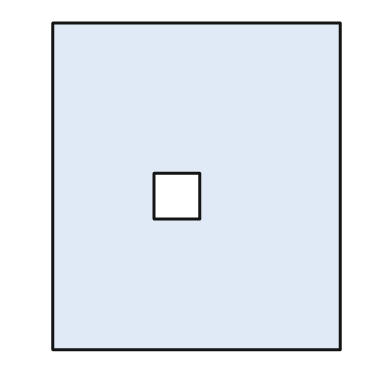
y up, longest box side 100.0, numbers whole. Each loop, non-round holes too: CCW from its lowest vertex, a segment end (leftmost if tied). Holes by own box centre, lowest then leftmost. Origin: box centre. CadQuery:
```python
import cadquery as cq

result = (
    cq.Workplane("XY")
    .moveTo(-44.0, -50.0)
    .lineTo(44.0, -50.0)
    .lineTo(44.0, 50.0)
    .lineTo(-44.0, 50.0)
    .close()
    .moveTo(-13.0, -10.0)
    .lineTo(1.0, -10.0)
    .lineTo(1.0, 4.0)
    .lineTo(-13.0, 4.0)
    .close()
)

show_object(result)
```